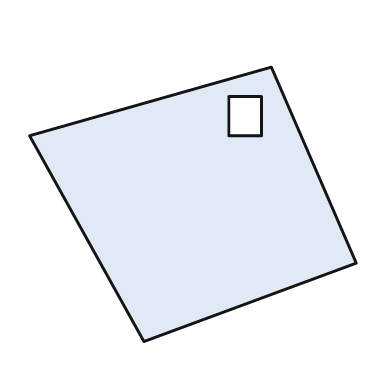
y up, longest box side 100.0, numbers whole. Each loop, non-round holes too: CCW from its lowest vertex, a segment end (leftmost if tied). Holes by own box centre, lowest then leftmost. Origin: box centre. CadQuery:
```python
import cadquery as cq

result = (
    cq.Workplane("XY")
    .moveTo(-15.0, -42.0)
    .lineTo(50.0, -18.0)
    .lineTo(24.0, 42.0)
    .lineTo(-50.0, 21.0)
    .close()
    .moveTo(11.0, 21.0)
    .lineTo(21.0, 21.0)
    .lineTo(21.0, 33.0)
    .lineTo(11.0, 33.0)
    .close()
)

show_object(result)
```